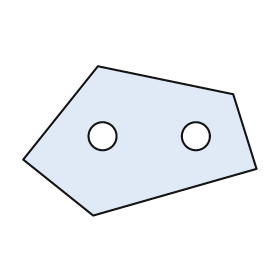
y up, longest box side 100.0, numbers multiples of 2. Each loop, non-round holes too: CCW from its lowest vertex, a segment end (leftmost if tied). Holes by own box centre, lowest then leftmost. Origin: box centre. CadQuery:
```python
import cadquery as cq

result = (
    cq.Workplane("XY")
    .moveTo(-20.0, -32.0)
    .lineTo(50.0, -12.0)
    .lineTo(40.0, 20.0)
    .lineTo(-18.0, 32.0)
    .lineTo(-50.0, -8.0)
    .close()
    .moveTo(-16.0, 2.0)
    .circle(6.0)
    .moveTo(24.0, 2.0)
    .circle(6.0)
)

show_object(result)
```